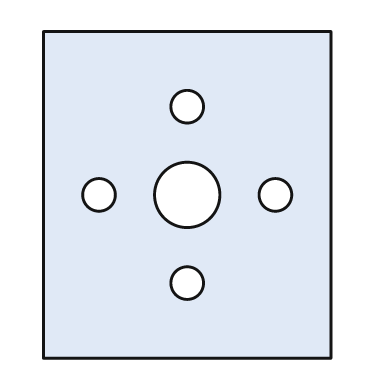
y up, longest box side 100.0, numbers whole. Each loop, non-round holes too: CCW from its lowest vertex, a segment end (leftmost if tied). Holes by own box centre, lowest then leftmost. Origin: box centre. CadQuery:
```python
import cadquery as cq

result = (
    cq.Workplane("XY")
    .moveTo(-44.0, -50.0)
    .lineTo(44.0, -50.0)
    .lineTo(44.0, 50.0)
    .lineTo(-44.0, 50.0)
    .close()
    .moveTo(0.0, -27.0)
    .circle(5.0)
    .moveTo(-27.0, 0.0)
    .circle(5.0)
    .moveTo(0.0, 0.0)
    .circle(10.0)
    .moveTo(27.0, 0.0)
    .circle(5.0)
    .moveTo(0.0, 27.0)
    .circle(5.0)
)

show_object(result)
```